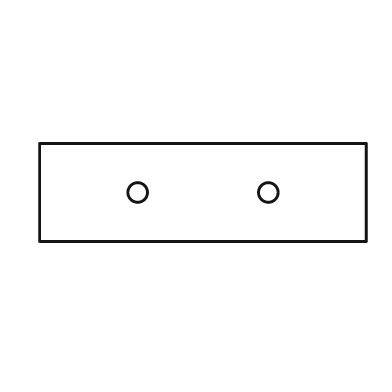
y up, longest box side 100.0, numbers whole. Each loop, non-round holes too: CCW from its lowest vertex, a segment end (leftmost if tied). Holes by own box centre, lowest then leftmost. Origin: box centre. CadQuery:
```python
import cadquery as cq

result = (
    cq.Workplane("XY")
    .moveTo(-50.0, -15.0)
    .lineTo(50.0, -15.0)
    .lineTo(50.0, 15.0)
    .lineTo(-50.0, 15.0)
    .close()
    .moveTo(-20.0, 0.0)
    .circle(3.0)
    .moveTo(20.0, 0.0)
    .circle(3.0)
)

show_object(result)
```